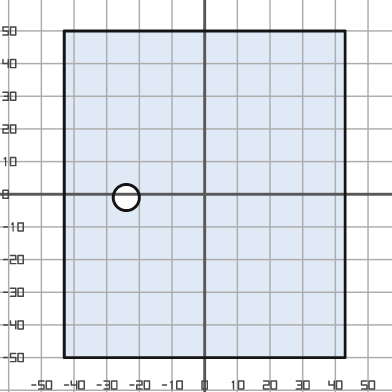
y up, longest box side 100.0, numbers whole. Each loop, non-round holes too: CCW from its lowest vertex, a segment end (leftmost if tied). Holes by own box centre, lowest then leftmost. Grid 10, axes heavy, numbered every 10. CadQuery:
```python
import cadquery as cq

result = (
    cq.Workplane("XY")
    .moveTo(-43.0, -50.0)
    .lineTo(43.0, -50.0)
    .lineTo(43.0, 50.0)
    .lineTo(-43.0, 50.0)
    .close()
    .moveTo(-24.0, -1.0)
    .circle(4.0)
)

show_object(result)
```